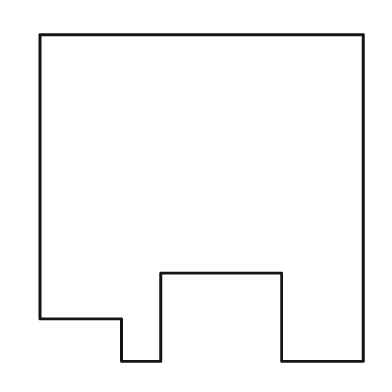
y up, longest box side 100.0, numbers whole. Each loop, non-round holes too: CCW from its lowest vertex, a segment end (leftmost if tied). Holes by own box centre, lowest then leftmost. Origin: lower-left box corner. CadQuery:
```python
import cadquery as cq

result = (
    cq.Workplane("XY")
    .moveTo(25.0, 0.0)
    .lineTo(37.0, 0.0)
    .lineTo(37.0, 27.0)
    .lineTo(74.0, 27.0)
    .lineTo(74.0, 0.0)
    .lineTo(99.0, 0.0)
    .lineTo(99.0, 100.0)
    .lineTo(0.0, 100.0)
    .lineTo(0.0, 13.0)
    .lineTo(25.0, 13.0)
    .close()
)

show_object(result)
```